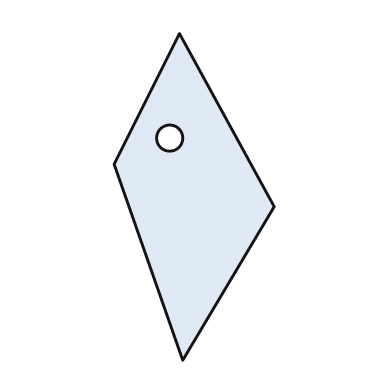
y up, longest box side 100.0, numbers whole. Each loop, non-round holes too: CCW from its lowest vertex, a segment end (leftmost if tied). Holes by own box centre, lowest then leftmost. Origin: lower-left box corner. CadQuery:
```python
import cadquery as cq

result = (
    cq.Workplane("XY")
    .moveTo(21.0, 0.0)
    .lineTo(49.0, 47.0)
    .lineTo(20.0, 100.0)
    .lineTo(0.0, 60.0)
    .close()
    .moveTo(17.0, 68.0)
    .circle(4.0)
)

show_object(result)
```